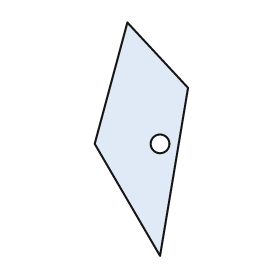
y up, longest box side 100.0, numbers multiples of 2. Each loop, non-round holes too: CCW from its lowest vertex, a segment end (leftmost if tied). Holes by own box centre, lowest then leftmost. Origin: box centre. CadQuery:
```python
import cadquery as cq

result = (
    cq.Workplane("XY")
    .moveTo(8.0, -50.0)
    .lineTo(20.0, 22.0)
    .lineTo(-6.0, 50.0)
    .lineTo(-20.0, -2.0)
    .close()
    .moveTo(8.0, -2.0)
    .circle(4.0)
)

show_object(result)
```